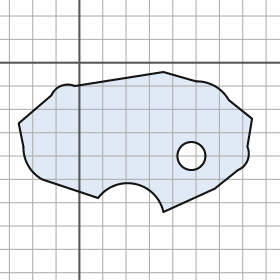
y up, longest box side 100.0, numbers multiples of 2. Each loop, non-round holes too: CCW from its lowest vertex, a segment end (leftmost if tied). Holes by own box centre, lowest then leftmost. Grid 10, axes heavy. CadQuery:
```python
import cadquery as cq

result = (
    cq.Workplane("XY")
    .moveTo(36.0, -64.0)
    .lineTo(58.0, -54.0)
    .lineTo(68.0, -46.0)
    .threePointArc((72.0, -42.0), (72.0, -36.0))
    .lineTo(74.0, -24.0)
    .lineTo(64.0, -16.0)
    .threePointArc((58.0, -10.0), (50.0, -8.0))
    .lineTo(36.0, -4.0)
    .lineTo(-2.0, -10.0)
    .threePointArc((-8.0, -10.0), (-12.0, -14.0))
    .lineTo(-26.0, -26.0)
    .lineTo(-24.0, -36.0)
    .threePointArc((-22.0, -44.0), (-16.0, -50.0))
    .lineTo(8.0, -58.0)
    .threePointArc((24.0, -52.0), (36.0, -64.0))
    .close()
    .moveTo(48.0, -40.0)
    .circle(6.0)
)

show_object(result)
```